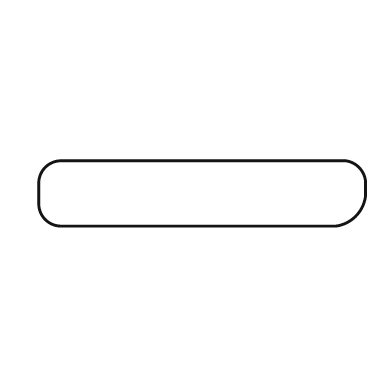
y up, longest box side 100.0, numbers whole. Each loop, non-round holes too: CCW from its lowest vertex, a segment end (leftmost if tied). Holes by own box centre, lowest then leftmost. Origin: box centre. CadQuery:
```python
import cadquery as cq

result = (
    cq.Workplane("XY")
    .moveTo(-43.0, -10.0)
    .lineTo(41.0, -10.0)
    .threePointArc((47.0, -7.0), (50.0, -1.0))
    .lineTo(50.0, 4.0)
    .threePointArc((48.0, 8.0), (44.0, 10.0))
    .lineTo(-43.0, 10.0)
    .threePointArc((-48.0, 8.0), (-50.0, 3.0))
    .lineTo(-50.0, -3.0)
    .threePointArc((-48.0, -8.0), (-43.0, -10.0))
    .close()
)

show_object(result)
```